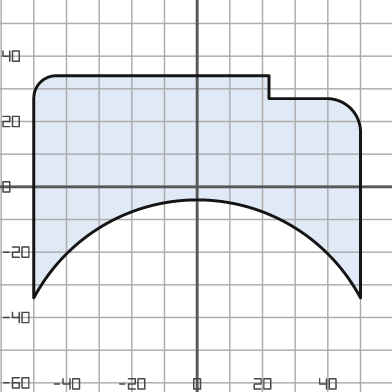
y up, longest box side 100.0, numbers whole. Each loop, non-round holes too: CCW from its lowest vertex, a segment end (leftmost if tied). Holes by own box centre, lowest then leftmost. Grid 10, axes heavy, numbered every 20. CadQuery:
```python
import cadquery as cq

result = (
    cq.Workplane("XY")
    .moveTo(-50.0, -34.0)
    .threePointArc((0.0, -4.0), (50.0, -34.0))
    .lineTo(50.0, 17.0)
    .threePointArc((47.0, 24.0), (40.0, 27.0))
    .lineTo(22.0, 27.0)
    .lineTo(22.0, 34.0)
    .lineTo(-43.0, 34.0)
    .threePointArc((-48.0, 32.0), (-50.0, 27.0))
    .close()
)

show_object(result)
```